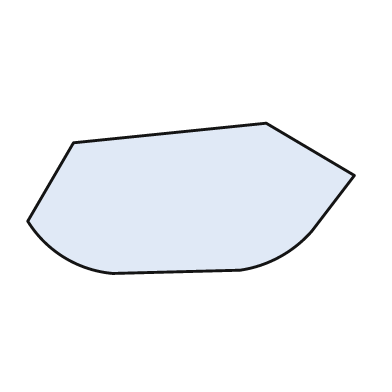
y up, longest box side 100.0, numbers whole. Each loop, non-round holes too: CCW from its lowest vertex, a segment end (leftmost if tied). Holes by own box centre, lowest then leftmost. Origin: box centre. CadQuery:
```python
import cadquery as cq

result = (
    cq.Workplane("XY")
    .moveTo(-24.0, -23.0)
    .lineTo(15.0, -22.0)
    .threePointArc((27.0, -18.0), (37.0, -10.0))
    .lineTo(50.0, 7.0)
    .lineTo(23.0, 23.0)
    .lineTo(-36.0, 17.0)
    .lineTo(-50.0, -7.0)
    .threePointArc((-39.0, -18.0), (-24.0, -23.0))
    .close()
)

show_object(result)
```